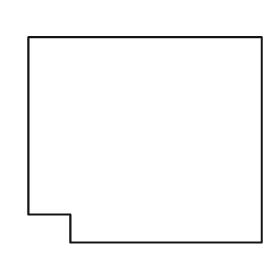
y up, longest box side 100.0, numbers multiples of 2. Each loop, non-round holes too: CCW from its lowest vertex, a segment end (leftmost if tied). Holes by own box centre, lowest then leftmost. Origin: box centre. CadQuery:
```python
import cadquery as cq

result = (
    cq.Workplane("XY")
    .moveTo(-32.0, -44.0)
    .lineTo(50.0, -44.0)
    .lineTo(50.0, 44.0)
    .lineTo(-50.0, 44.0)
    .lineTo(-50.0, -32.0)
    .lineTo(-32.0, -32.0)
    .close()
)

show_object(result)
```